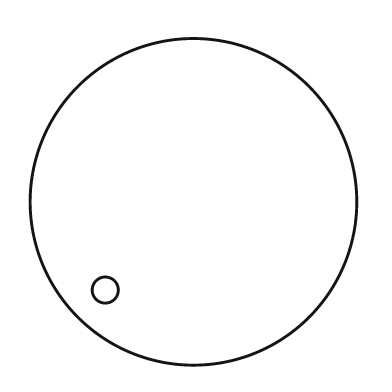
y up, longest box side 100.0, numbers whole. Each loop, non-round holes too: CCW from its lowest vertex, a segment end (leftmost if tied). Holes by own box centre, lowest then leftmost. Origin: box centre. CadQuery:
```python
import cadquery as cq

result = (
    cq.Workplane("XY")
    .moveTo(0.0, 0.0)
    .circle(50.0)
    .moveTo(-27.0, -27.0)
    .circle(4.0)
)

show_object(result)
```